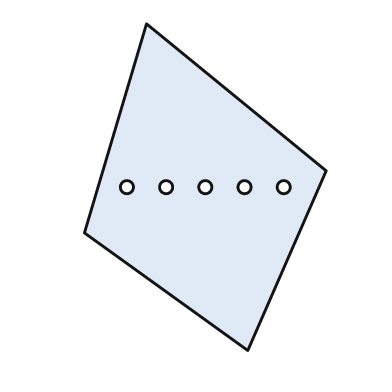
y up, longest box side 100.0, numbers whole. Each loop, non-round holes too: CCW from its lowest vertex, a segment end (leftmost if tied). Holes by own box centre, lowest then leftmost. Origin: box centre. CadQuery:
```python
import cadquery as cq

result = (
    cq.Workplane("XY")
    .moveTo(13.0, -50.0)
    .lineTo(37.0, 5.0)
    .lineTo(-18.0, 50.0)
    .lineTo(-37.0, -14.0)
    .close()
    .moveTo(-24.0, 0.0)
    .circle(2.0)
    .moveTo(-12.0, 0.0)
    .circle(2.0)
    .moveTo(0.0, 0.0)
    .circle(2.0)
    .moveTo(12.0, 0.0)
    .circle(2.0)
    .moveTo(24.0, 0.0)
    .circle(2.0)
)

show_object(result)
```